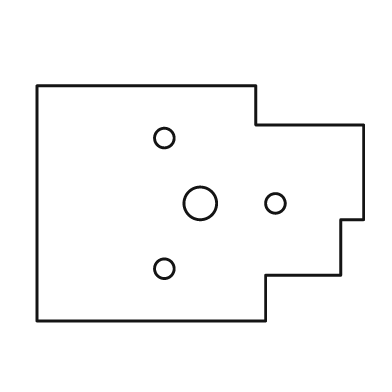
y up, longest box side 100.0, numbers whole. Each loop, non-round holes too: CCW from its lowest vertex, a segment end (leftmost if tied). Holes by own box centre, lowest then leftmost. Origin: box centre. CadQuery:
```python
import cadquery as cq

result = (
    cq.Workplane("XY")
    .moveTo(-50.0, -36.0)
    .lineTo(20.0, -36.0)
    .lineTo(20.0, -22.0)
    .lineTo(43.0, -22.0)
    .lineTo(43.0, -5.0)
    .lineTo(50.0, -5.0)
    .lineTo(50.0, 24.0)
    .lineTo(17.0, 24.0)
    .lineTo(17.0, 36.0)
    .lineTo(-50.0, 36.0)
    .close()
    .moveTo(-11.0, -20.0)
    .circle(3.0)
    .moveTo(0.0, 0.0)
    .circle(5.0)
    .moveTo(23.0, 0.0)
    .circle(3.0)
    .moveTo(-11.0, 20.0)
    .circle(3.0)
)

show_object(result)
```